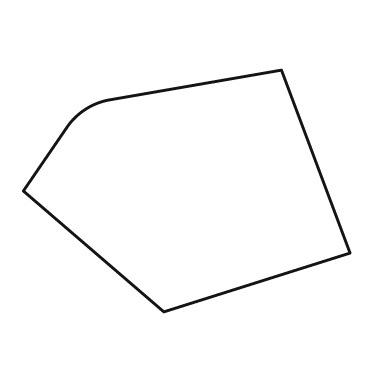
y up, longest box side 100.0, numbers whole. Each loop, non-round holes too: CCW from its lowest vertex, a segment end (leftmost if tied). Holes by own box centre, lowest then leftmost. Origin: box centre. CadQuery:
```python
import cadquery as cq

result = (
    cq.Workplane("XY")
    .moveTo(-7.0, -37.0)
    .lineTo(50.0, -19.0)
    .lineTo(29.0, 37.0)
    .lineTo(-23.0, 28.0)
    .threePointArc((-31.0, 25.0), (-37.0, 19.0))
    .lineTo(-50.0, 0.0)
    .close()
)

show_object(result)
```